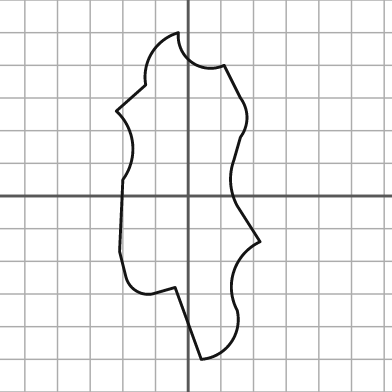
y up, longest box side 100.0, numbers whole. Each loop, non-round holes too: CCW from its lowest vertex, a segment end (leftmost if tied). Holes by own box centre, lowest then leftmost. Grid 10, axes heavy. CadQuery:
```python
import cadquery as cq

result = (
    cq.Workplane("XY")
    .moveTo(4.0, -50.0)
    .threePointArc((13.0, -45.0), (15.0, -35.0))
    .threePointArc((14.0, -23.0), (22.0, -14.0))
    .lineTo(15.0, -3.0)
    .threePointArc((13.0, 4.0), (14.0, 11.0))
    .lineTo(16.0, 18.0)
    .threePointArc((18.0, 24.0), (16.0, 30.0))
    .lineTo(11.0, 40.0)
    .threePointArc((1.0, 41.0), (-3.0, 50.0))
    .threePointArc((-11.0, 44.0), (-13.0, 34.0))
    .lineTo(-22.0, 26.0)
    .threePointArc((-17.0, 16.0), (-20.0, 5.0))
    .lineTo(-21.0, -17.0)
    .lineTo(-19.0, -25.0)
    .threePointArc((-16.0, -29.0), (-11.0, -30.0))
    .lineTo(-4.0, -28.0)
    .close()
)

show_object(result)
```